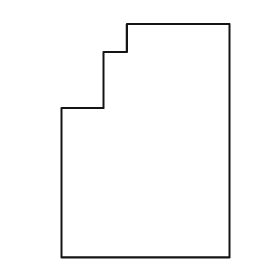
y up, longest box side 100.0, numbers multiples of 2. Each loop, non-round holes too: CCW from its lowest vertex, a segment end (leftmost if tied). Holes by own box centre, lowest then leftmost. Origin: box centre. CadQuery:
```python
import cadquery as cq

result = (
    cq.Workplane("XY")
    .moveTo(-36.0, -50.0)
    .lineTo(36.0, -50.0)
    .lineTo(36.0, 50.0)
    .lineTo(-8.0, 50.0)
    .lineTo(-8.0, 38.0)
    .lineTo(-18.0, 38.0)
    .lineTo(-18.0, 14.0)
    .lineTo(-36.0, 14.0)
    .close()
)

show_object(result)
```